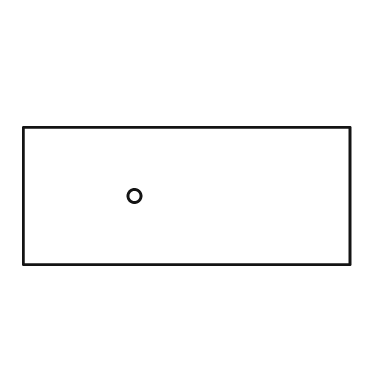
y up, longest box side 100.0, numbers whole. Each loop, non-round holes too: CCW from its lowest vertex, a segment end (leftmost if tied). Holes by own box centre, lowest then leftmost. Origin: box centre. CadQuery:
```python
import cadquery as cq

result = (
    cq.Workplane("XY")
    .moveTo(-50.0, -21.0)
    .lineTo(50.0, -21.0)
    .lineTo(50.0, 21.0)
    .lineTo(-50.0, 21.0)
    .close()
    .moveTo(-16.0, 0.0)
    .circle(2.0)
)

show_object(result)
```